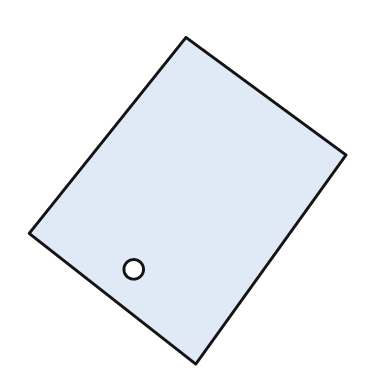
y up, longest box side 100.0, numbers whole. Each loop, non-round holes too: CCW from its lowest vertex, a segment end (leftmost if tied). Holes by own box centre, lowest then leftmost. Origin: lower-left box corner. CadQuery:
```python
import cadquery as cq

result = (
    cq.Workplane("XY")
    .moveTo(51.0, 0.0)
    .lineTo(97.0, 64.0)
    .lineTo(48.0, 100.0)
    .lineTo(0.0, 40.0)
    .close()
    .moveTo(32.0, 29.0)
    .circle(3.0)
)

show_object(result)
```